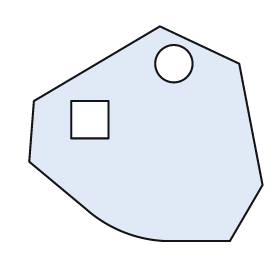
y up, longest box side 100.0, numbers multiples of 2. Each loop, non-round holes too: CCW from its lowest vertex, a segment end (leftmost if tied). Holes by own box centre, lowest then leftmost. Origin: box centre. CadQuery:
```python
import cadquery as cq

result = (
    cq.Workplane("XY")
    .moveTo(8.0, -46.0)
    .lineTo(36.0, -46.0)
    .lineTo(50.0, -22.0)
    .lineTo(40.0, 30.0)
    .lineTo(6.0, 46.0)
    .lineTo(-48.0, 14.0)
    .lineTo(-50.0, -12.0)
    .lineTo(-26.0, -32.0)
    .threePointArc((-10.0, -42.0), (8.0, -46.0))
    .close()
    .moveTo(-32.0, -2.0)
    .lineTo(-16.0, -2.0)
    .lineTo(-16.0, 14.0)
    .lineTo(-32.0, 14.0)
    .close()
    .moveTo(12.0, 30.0)
    .circle(8.0)
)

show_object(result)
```